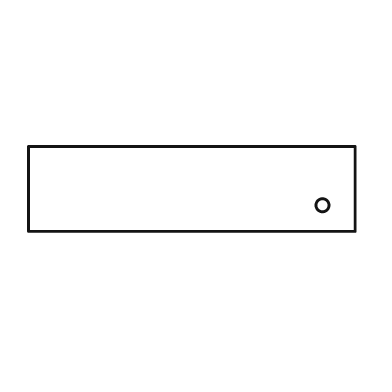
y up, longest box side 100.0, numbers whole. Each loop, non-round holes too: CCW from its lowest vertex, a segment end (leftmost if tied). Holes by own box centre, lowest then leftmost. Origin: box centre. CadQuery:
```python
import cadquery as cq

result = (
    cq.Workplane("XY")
    .moveTo(-50.0, -13.0)
    .lineTo(50.0, -13.0)
    .lineTo(50.0, 13.0)
    .lineTo(-50.0, 13.0)
    .close()
    .moveTo(40.0, -5.0)
    .circle(2.0)
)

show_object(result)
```